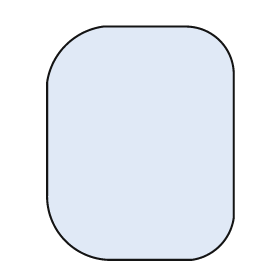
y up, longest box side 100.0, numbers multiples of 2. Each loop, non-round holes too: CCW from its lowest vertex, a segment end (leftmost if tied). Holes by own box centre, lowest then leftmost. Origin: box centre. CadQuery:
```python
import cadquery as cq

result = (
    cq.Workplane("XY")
    .moveTo(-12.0, -50.0)
    .lineTo(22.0, -50.0)
    .threePointArc((34.0, -44.0), (40.0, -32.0))
    .lineTo(40.0, 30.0)
    .threePointArc((34.0, 44.0), (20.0, 50.0))
    .lineTo(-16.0, 50.0)
    .threePointArc((-32.0, 42.0), (-40.0, 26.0))
    .lineTo(-40.0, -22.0)
    .threePointArc((-32.0, -42.0), (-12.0, -50.0))
    .close()
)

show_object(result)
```